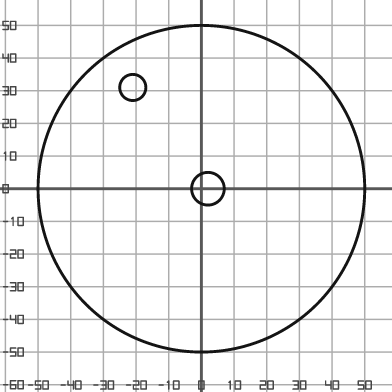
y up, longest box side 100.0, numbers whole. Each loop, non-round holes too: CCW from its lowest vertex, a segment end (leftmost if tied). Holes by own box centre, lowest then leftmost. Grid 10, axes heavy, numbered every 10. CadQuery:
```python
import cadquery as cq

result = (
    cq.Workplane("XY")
    .moveTo(0.0, 0.0)
    .circle(50.0)
    .moveTo(2.0, 0.0)
    .circle(5.0)
    .moveTo(-21.0, 31.0)
    .circle(4.0)
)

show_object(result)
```